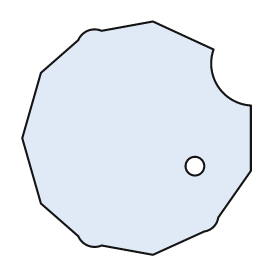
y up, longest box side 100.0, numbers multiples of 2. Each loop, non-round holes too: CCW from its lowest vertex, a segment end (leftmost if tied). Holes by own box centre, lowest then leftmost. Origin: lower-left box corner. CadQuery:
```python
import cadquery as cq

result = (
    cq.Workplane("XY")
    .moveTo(56.0, 0.0)
    .lineTo(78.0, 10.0)
    .threePointArc((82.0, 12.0), (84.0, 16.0))
    .lineTo(98.0, 36.0)
    .lineTo(98.0, 64.0)
    .threePointArc((84.0, 72.0), (82.0, 88.0))
    .lineTo(56.0, 100.0)
    .lineTo(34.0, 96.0)
    .threePointArc((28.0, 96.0), (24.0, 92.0))
    .lineTo(8.0, 78.0)
    .lineTo(0.0, 50.0)
    .lineTo(8.0, 22.0)
    .lineTo(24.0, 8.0)
    .threePointArc((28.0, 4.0), (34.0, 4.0))
    .close()
    .moveTo(74.0, 38.0)
    .circle(4.0)
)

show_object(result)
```